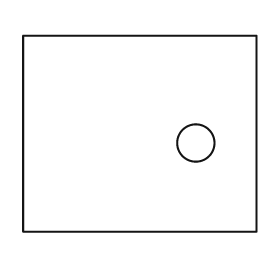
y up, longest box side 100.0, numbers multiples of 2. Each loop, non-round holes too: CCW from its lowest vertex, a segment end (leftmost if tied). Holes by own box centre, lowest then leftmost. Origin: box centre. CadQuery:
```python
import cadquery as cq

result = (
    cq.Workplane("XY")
    .moveTo(-50.0, -42.0)
    .lineTo(50.0, -42.0)
    .lineTo(50.0, 42.0)
    .lineTo(-50.0, 42.0)
    .close()
    .moveTo(24.0, -4.0)
    .circle(8.0)
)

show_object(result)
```